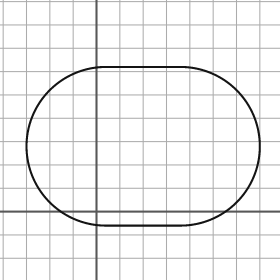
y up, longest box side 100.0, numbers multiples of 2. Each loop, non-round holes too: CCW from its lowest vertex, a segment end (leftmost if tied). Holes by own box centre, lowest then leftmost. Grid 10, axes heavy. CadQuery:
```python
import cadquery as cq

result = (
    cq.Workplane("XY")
    .moveTo(4.0, -6.0)
    .lineTo(36.0, -6.0)
    .threePointArc((70.0, 28.0), (36.0, 62.0))
    .lineTo(4.0, 62.0)
    .threePointArc((-30.0, 28.0), (4.0, -6.0))
    .close()
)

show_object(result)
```